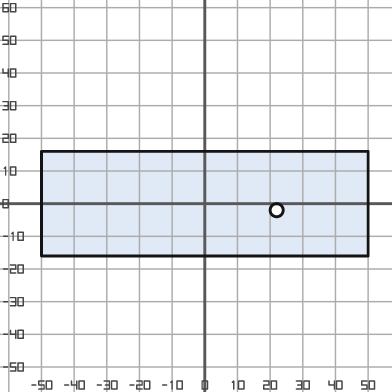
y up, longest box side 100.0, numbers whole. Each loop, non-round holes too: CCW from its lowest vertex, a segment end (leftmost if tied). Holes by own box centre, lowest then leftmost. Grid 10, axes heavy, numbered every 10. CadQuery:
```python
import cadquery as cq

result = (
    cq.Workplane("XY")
    .moveTo(-50.0, -16.0)
    .lineTo(50.0, -16.0)
    .lineTo(50.0, 16.0)
    .lineTo(-50.0, 16.0)
    .close()
    .moveTo(22.0, -2.0)
    .circle(2.0)
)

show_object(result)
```